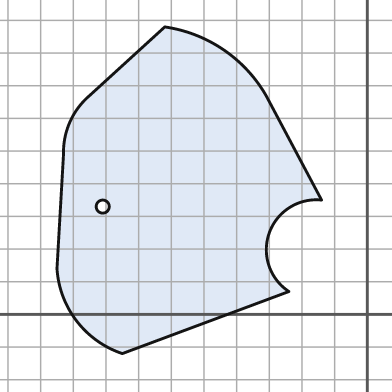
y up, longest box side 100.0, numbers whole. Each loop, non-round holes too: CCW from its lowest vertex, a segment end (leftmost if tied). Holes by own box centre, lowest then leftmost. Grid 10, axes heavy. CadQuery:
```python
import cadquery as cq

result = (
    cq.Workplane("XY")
    .moveTo(-75.0, -12.0)
    .lineTo(-24.0, 7.0)
    .threePointArc((-30.0, 25.0), (-14.0, 35.0))
    .lineTo(-31.0, 67.0)
    .threePointArc((-44.0, 81.0), (-62.0, 88.0))
    .lineTo(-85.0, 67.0)
    .threePointArc((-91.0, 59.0), (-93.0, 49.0))
    .lineTo(-95.0, 14.0)
    .threePointArc((-89.0, -2.0), (-75.0, -12.0))
    .close()
    .moveTo(-81.0, 33.0)
    .circle(2.0)
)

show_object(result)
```